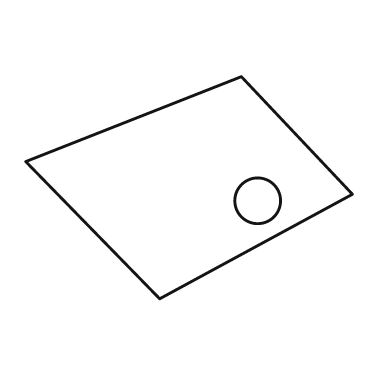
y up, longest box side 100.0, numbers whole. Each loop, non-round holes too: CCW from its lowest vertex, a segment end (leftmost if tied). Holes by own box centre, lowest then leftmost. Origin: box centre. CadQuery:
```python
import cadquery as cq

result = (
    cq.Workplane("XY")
    .moveTo(-9.0, -34.0)
    .lineTo(50.0, -2.0)
    .lineTo(16.0, 34.0)
    .lineTo(-50.0, 8.0)
    .close()
    .moveTo(21.0, -4.0)
    .circle(7.0)
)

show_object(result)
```